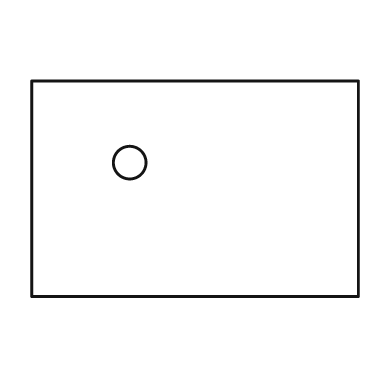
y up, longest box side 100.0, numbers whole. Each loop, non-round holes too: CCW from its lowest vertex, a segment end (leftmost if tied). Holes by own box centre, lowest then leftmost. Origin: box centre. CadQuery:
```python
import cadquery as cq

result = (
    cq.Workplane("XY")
    .moveTo(-50.0, -33.0)
    .lineTo(50.0, -33.0)
    .lineTo(50.0, 33.0)
    .lineTo(-50.0, 33.0)
    .close()
    .moveTo(-20.0, 8.0)
    .circle(5.0)
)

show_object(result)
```